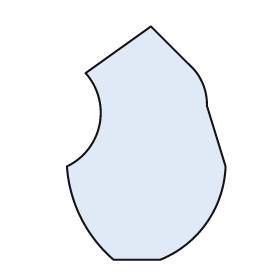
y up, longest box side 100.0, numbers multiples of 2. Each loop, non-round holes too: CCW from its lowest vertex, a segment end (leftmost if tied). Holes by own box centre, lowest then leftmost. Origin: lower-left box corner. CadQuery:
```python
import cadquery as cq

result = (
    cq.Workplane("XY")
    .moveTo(20.0, 0.0)
    .lineTo(40.0, 0.0)
    .threePointArc((60.0, 16.0), (68.0, 40.0))
    .lineTo(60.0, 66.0)
    .threePointArc((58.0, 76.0), (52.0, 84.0))
    .lineTo(36.0, 100.0)
    .lineTo(8.0, 80.0)
    .threePointArc((14.0, 58.0), (0.0, 40.0))
    .threePointArc((6.0, 18.0), (20.0, 0.0))
    .close()
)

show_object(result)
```